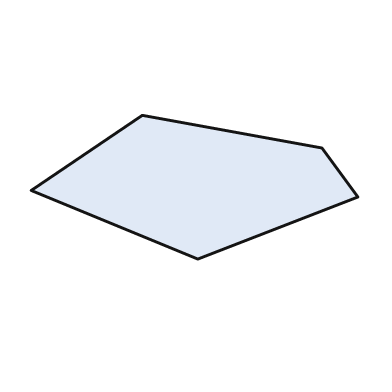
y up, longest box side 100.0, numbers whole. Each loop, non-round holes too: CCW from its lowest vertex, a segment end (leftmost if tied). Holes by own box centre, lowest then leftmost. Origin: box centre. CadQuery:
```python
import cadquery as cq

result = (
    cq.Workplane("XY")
    .moveTo(1.0, -22.0)
    .lineTo(50.0, -3.0)
    .lineTo(39.0, 12.0)
    .lineTo(-16.0, 22.0)
    .lineTo(-50.0, -1.0)
    .close()
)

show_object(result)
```